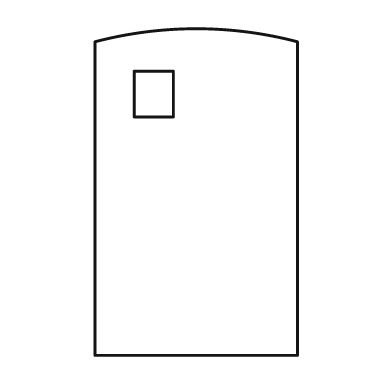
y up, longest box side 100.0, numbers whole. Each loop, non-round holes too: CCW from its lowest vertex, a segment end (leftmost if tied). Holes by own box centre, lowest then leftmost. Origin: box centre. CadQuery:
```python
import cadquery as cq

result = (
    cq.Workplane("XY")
    .moveTo(-31.0, -50.0)
    .lineTo(31.0, -50.0)
    .lineTo(31.0, 46.0)
    .threePointArc((0.0, 50.0), (-31.0, 46.0))
    .close()
    .moveTo(-19.0, 23.0)
    .lineTo(-7.0, 23.0)
    .lineTo(-7.0, 37.0)
    .lineTo(-19.0, 37.0)
    .close()
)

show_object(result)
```